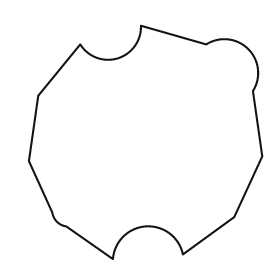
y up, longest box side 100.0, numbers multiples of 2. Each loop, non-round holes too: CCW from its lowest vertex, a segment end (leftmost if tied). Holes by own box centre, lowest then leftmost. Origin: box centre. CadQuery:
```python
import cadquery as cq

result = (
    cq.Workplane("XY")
    .moveTo(-14.0, -50.0)
    .threePointArc((0.0, -36.0), (16.0, -48.0))
    .lineTo(38.0, -32.0)
    .lineTo(50.0, -6.0)
    .lineTo(46.0, 22.0)
    .threePointArc((44.0, 40.0), (26.0, 42.0))
    .lineTo(-2.0, 50.0)
    .threePointArc((-12.0, 36.0), (-28.0, 42.0))
    .lineTo(-46.0, 20.0)
    .lineTo(-50.0, -8.0)
    .lineTo(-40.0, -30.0)
    .threePointArc((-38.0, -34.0), (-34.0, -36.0))
    .close()
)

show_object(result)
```